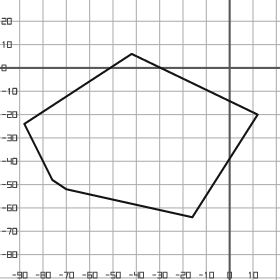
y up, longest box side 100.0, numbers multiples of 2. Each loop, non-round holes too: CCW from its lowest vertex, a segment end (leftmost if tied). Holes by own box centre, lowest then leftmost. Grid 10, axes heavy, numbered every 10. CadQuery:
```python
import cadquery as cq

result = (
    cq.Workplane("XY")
    .moveTo(-16.0, -64.0)
    .lineTo(12.0, -20.0)
    .lineTo(-42.0, 6.0)
    .lineTo(-88.0, -24.0)
    .lineTo(-76.0, -48.0)
    .lineTo(-70.0, -52.0)
    .close()
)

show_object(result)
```